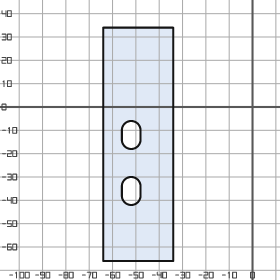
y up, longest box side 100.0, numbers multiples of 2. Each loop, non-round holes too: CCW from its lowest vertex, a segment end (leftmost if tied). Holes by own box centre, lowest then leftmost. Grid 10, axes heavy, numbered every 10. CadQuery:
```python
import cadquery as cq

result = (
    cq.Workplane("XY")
    .moveTo(-64.0, -66.0)
    .lineTo(-34.0, -66.0)
    .lineTo(-34.0, 34.0)
    .lineTo(-64.0, 34.0)
    .close()
    .moveTo(-56.0, -38.0)
    .threePointArc((-52.0, -42.0), (-48.0, -38.0))
    .lineTo(-48.0, -34.0)
    .threePointArc((-52.0, -30.0), (-56.0, -34.0))
    .close()
    .moveTo(-56.0, -14.0)
    .threePointArc((-52.0, -18.0), (-48.0, -14.0))
    .lineTo(-48.0, -10.0)
    .threePointArc((-52.0, -6.0), (-56.0, -10.0))
    .close()
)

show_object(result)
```